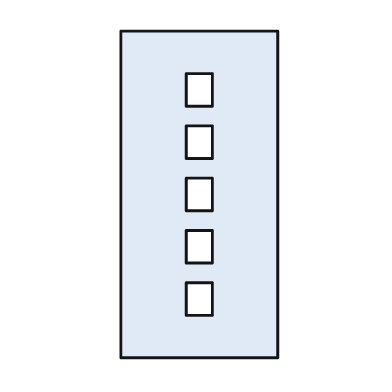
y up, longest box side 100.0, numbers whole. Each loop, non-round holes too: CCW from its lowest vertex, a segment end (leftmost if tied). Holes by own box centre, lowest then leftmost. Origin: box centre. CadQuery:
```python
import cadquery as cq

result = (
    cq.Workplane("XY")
    .moveTo(-24.0, -50.0)
    .lineTo(24.0, -50.0)
    .lineTo(24.0, 50.0)
    .lineTo(-24.0, 50.0)
    .close()
    .moveTo(-4.0, -37.0)
    .lineTo(4.0, -37.0)
    .lineTo(4.0, -27.0)
    .lineTo(-4.0, -27.0)
    .close()
    .moveTo(-4.0, -21.0)
    .lineTo(4.0, -21.0)
    .lineTo(4.0, -11.0)
    .lineTo(-4.0, -11.0)
    .close()
    .moveTo(-4.0, -5.0)
    .lineTo(4.0, -5.0)
    .lineTo(4.0, 5.0)
    .lineTo(-4.0, 5.0)
    .close()
    .moveTo(-4.0, 11.0)
    .lineTo(4.0, 11.0)
    .lineTo(4.0, 21.0)
    .lineTo(-4.0, 21.0)
    .close()
    .moveTo(-4.0, 27.0)
    .lineTo(4.0, 27.0)
    .lineTo(4.0, 37.0)
    .lineTo(-4.0, 37.0)
    .close()
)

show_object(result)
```